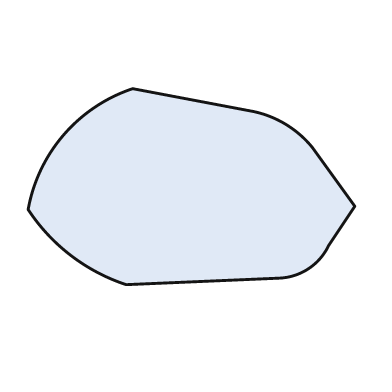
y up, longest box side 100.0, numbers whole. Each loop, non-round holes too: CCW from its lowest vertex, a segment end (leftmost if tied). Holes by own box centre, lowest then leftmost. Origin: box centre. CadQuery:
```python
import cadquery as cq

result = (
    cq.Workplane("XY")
    .moveTo(-20.0, -30.0)
    .lineTo(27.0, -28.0)
    .threePointArc((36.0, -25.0), (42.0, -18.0))
    .lineTo(50.0, -6.0)
    .lineTo(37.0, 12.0)
    .threePointArc((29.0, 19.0), (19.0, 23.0))
    .lineTo(-18.0, 30.0)
    .threePointArc((-39.0, 16.0), (-50.0, -7.0))
    .threePointArc((-37.0, -21.0), (-20.0, -30.0))
    .close()
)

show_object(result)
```